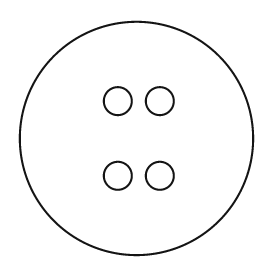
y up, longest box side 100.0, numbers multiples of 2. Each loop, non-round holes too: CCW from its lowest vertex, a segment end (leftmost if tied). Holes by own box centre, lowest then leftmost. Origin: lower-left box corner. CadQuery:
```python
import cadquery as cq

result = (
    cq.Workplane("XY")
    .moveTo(50.0, 50.0)
    .circle(50.0)
    .moveTo(42.0, 34.0)
    .circle(6.0)
    .moveTo(60.0, 34.0)
    .circle(6.0)
    .moveTo(42.0, 66.0)
    .circle(6.0)
    .moveTo(60.0, 66.0)
    .circle(6.0)
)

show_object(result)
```